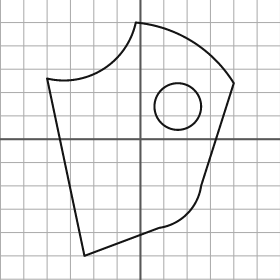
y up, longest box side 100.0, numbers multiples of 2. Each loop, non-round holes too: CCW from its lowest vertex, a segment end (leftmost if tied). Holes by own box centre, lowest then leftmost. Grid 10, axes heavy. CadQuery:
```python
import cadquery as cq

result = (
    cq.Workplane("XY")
    .moveTo(-24.0, -50.0)
    .lineTo(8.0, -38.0)
    .threePointArc((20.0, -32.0), (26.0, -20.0))
    .lineTo(40.0, 24.0)
    .threePointArc((22.0, 42.0), (-2.0, 50.0))
    .threePointArc((-16.0, 30.0), (-40.0, 26.0))
    .close()
    .moveTo(16.0, 14.0)
    .circle(10.0)
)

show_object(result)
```